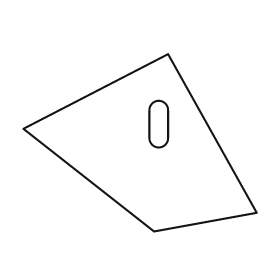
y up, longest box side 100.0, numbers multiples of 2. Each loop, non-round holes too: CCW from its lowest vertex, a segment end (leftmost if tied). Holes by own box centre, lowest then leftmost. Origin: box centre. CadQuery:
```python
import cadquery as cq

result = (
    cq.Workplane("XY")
    .moveTo(6.0, -38.0)
    .lineTo(50.0, -30.0)
    .lineTo(12.0, 38.0)
    .lineTo(-50.0, 6.0)
    .close()
    .moveTo(4.0, 2.0)
    .threePointArc((8.0, -2.0), (12.0, 2.0))
    .lineTo(12.0, 14.0)
    .threePointArc((8.0, 18.0), (4.0, 14.0))
    .close()
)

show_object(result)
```